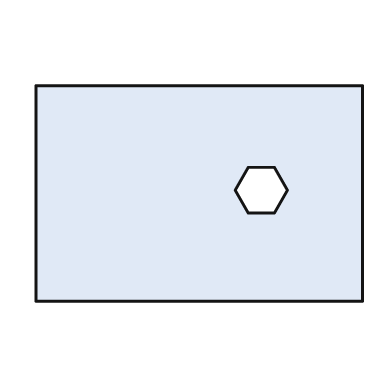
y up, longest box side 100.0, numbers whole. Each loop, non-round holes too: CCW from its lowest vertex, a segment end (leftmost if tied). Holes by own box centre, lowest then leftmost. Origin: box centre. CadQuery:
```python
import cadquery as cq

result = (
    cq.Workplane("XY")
    .moveTo(-50.0, -33.0)
    .lineTo(50.0, -33.0)
    .lineTo(50.0, 33.0)
    .lineTo(-50.0, 33.0)
    .close()
    .moveTo(15.0, -6.0)
    .lineTo(23.0, -6.0)
    .lineTo(27.0, 1.0)
    .lineTo(23.0, 8.0)
    .lineTo(15.0, 8.0)
    .lineTo(11.0, 1.0)
    .close()
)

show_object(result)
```